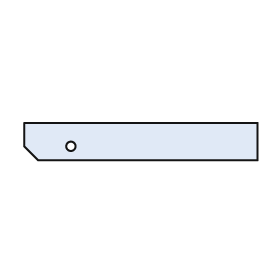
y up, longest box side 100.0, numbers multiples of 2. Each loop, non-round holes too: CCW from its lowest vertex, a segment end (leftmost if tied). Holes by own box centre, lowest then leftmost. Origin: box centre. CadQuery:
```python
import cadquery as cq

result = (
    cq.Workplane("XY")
    .moveTo(-44.0, -8.0)
    .lineTo(50.0, -8.0)
    .lineTo(50.0, 8.0)
    .lineTo(-50.0, 8.0)
    .lineTo(-50.0, -2.0)
    .close()
    .moveTo(-30.0, -2.0)
    .circle(2.0)
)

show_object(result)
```